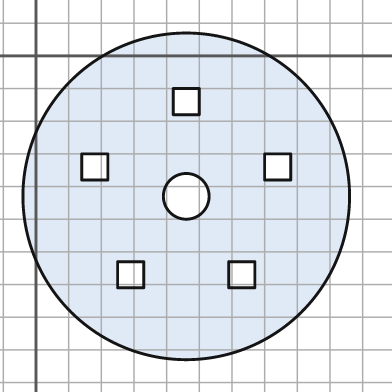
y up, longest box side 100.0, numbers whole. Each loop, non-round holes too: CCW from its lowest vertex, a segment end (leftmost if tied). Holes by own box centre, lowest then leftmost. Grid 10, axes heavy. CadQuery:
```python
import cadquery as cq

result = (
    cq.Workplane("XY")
    .moveTo(46.0, -43.0)
    .circle(50.0)
    .moveTo(25.0, -71.0)
    .lineTo(33.0, -71.0)
    .lineTo(33.0, -63.0)
    .lineTo(25.0, -63.0)
    .close()
    .moveTo(59.0, -71.0)
    .lineTo(67.0, -71.0)
    .lineTo(67.0, -63.0)
    .lineTo(59.0, -63.0)
    .close()
    .moveTo(46.0, -43.0)
    .circle(7.0)
    .moveTo(14.0, -38.0)
    .lineTo(22.0, -38.0)
    .lineTo(22.0, -30.0)
    .lineTo(14.0, -30.0)
    .close()
    .moveTo(70.0, -38.0)
    .lineTo(78.0, -38.0)
    .lineTo(78.0, -30.0)
    .lineTo(70.0, -30.0)
    .close()
    .moveTo(42.0, -18.0)
    .lineTo(50.0, -18.0)
    .lineTo(50.0, -10.0)
    .lineTo(42.0, -10.0)
    .close()
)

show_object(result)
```